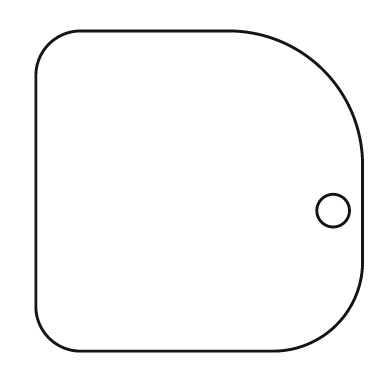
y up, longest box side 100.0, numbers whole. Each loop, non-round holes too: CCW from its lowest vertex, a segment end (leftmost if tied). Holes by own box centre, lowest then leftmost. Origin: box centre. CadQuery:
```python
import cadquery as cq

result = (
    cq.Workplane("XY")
    .moveTo(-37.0, -49.0)
    .lineTo(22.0, -49.0)
    .threePointArc((42.0, -41.0), (50.0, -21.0))
    .lineTo(50.0, 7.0)
    .threePointArc((38.0, 37.0), (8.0, 49.0))
    .lineTo(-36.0, 49.0)
    .threePointArc((-46.0, 45.0), (-50.0, 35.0))
    .lineTo(-50.0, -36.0)
    .threePointArc((-46.0, -45.0), (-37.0, -49.0))
    .close()
    .moveTo(41.0, -6.0)
    .circle(5.0)
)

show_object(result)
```